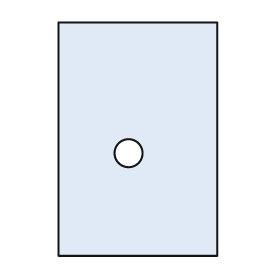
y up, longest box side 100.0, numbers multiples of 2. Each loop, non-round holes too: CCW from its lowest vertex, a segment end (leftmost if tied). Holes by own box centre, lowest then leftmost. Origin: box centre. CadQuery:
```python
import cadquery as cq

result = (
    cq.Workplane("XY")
    .moveTo(-34.0, -50.0)
    .lineTo(34.0, -50.0)
    .lineTo(34.0, 50.0)
    .lineTo(-34.0, 50.0)
    .close()
    .moveTo(-4.0, -6.0)
    .circle(6.0)
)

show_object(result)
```